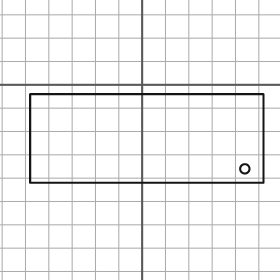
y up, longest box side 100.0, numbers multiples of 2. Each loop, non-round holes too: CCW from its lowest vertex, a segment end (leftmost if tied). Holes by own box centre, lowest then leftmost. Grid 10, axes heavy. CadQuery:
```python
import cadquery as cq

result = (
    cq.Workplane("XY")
    .moveTo(-48.0, -42.0)
    .lineTo(52.0, -42.0)
    .lineTo(52.0, -4.0)
    .lineTo(-48.0, -4.0)
    .close()
    .moveTo(44.0, -36.0)
    .circle(2.0)
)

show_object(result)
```